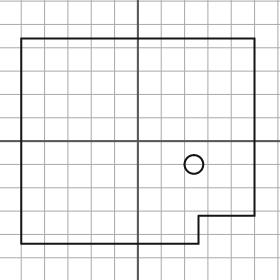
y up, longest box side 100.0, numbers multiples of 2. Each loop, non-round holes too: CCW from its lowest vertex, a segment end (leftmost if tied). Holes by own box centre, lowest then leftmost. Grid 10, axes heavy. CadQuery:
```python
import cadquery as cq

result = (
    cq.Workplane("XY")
    .moveTo(-50.0, -44.0)
    .lineTo(26.0, -44.0)
    .lineTo(26.0, -32.0)
    .lineTo(50.0, -32.0)
    .lineTo(50.0, 44.0)
    .lineTo(-50.0, 44.0)
    .close()
    .moveTo(24.0, -10.0)
    .circle(4.0)
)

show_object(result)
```